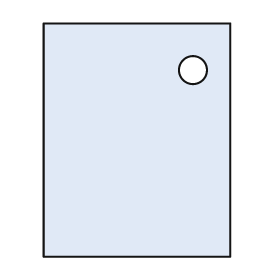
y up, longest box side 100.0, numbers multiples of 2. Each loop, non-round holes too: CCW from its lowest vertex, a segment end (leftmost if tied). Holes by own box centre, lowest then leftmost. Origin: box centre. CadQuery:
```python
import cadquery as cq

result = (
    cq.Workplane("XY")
    .moveTo(-40.0, -50.0)
    .lineTo(40.0, -50.0)
    .lineTo(40.0, 50.0)
    .lineTo(-40.0, 50.0)
    .close()
    .moveTo(24.0, 30.0)
    .circle(6.0)
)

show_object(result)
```